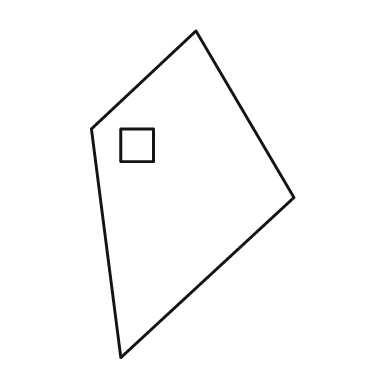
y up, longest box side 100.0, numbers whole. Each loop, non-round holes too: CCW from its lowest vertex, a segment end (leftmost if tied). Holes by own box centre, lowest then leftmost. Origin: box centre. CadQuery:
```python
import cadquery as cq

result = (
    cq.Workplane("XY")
    .moveTo(-22.0, -50.0)
    .lineTo(31.0, -1.0)
    .lineTo(1.0, 50.0)
    .lineTo(-31.0, 20.0)
    .close()
    .moveTo(-22.0, 10.0)
    .lineTo(-12.0, 10.0)
    .lineTo(-12.0, 20.0)
    .lineTo(-22.0, 20.0)
    .close()
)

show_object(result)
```